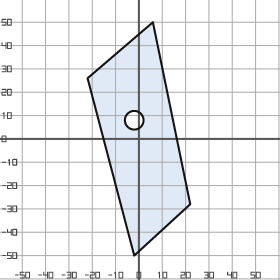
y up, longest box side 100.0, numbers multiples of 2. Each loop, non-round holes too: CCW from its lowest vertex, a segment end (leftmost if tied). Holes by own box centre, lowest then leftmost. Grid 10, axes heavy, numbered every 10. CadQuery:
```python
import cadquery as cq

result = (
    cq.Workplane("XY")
    .moveTo(-2.0, -50.0)
    .lineTo(22.0, -28.0)
    .lineTo(6.0, 50.0)
    .lineTo(-22.0, 26.0)
    .close()
    .moveTo(-2.0, 8.0)
    .circle(4.0)
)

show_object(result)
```